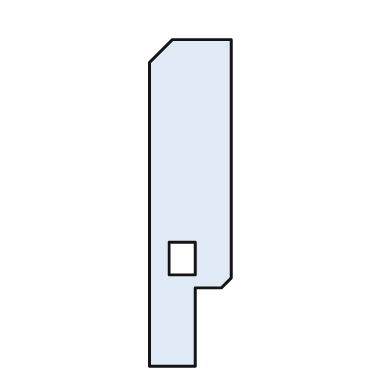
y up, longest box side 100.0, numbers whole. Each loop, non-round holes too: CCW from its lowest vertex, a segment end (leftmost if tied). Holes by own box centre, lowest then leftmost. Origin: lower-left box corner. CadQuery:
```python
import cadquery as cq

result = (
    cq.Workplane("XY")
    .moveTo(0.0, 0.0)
    .lineTo(14.0, 0.0)
    .lineTo(14.0, 24.0)
    .lineTo(22.0, 24.0)
    .lineTo(25.0, 27.0)
    .lineTo(25.0, 100.0)
    .lineTo(7.0, 100.0)
    .lineTo(0.0, 93.0)
    .close()
    .moveTo(6.0, 28.0)
    .lineTo(14.0, 28.0)
    .lineTo(14.0, 38.0)
    .lineTo(6.0, 38.0)
    .close()
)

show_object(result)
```